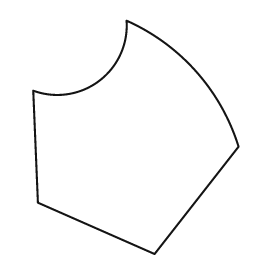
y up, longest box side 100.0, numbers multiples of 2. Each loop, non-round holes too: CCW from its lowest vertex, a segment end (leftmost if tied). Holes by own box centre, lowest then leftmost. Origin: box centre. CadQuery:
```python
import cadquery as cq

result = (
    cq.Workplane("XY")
    .moveTo(8.0, -50.0)
    .lineTo(44.0, -4.0)
    .threePointArc((26.0, 28.0), (-4.0, 50.0))
    .threePointArc((-16.0, 24.0), (-44.0, 20.0))
    .lineTo(-42.0, -28.0)
    .close()
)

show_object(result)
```